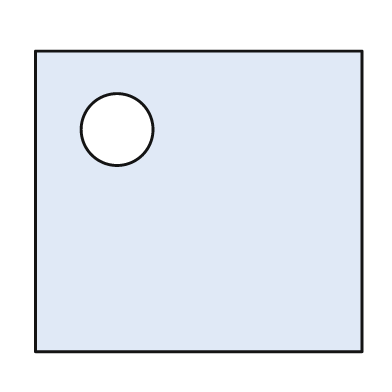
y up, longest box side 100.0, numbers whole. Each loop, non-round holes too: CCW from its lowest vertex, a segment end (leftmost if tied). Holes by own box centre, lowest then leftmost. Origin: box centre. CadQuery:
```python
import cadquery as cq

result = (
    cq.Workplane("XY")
    .moveTo(-50.0, -46.0)
    .lineTo(50.0, -46.0)
    .lineTo(50.0, 46.0)
    .lineTo(-50.0, 46.0)
    .close()
    .moveTo(-25.0, 22.0)
    .circle(11.0)
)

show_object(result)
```